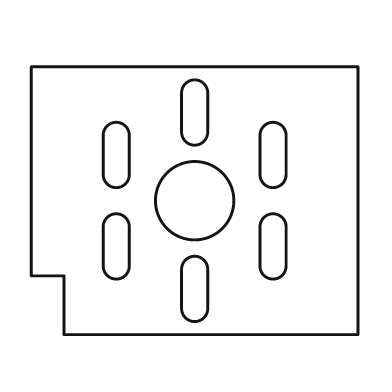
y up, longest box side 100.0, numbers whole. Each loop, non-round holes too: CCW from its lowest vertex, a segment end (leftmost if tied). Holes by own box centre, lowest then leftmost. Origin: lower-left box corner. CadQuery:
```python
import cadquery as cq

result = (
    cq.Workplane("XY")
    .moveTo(10.0, 0.0)
    .lineTo(100.0, 0.0)
    .lineTo(100.0, 82.0)
    .lineTo(0.0, 82.0)
    .lineTo(0.0, 18.0)
    .lineTo(10.0, 18.0)
    .close()
    .moveTo(46.0, 8.0)
    .threePointArc((50.0, 4.0), (54.0, 8.0))
    .lineTo(54.0, 20.0)
    .threePointArc((50.0, 24.0), (46.0, 20.0))
    .close()
    .moveTo(22.0, 21.0)
    .threePointArc((26.0, 17.0), (30.0, 21.0))
    .lineTo(30.0, 33.0)
    .threePointArc((26.0, 37.0), (22.0, 33.0))
    .close()
    .moveTo(70.0, 21.0)
    .threePointArc((74.0, 17.0), (78.0, 21.0))
    .lineTo(78.0, 33.0)
    .threePointArc((74.0, 37.0), (70.0, 33.0))
    .close()
    .moveTo(50.0, 41.0)
    .circle(12.0)
    .moveTo(22.0, 49.0)
    .threePointArc((26.0, 45.0), (30.0, 49.0))
    .lineTo(30.0, 61.0)
    .threePointArc((26.0, 65.0), (22.0, 61.0))
    .close()
    .moveTo(70.0, 49.0)
    .threePointArc((74.0, 45.0), (78.0, 49.0))
    .lineTo(78.0, 61.0)
    .threePointArc((74.0, 65.0), (70.0, 61.0))
    .close()
    .moveTo(46.0, 62.0)
    .threePointArc((50.0, 58.0), (54.0, 62.0))
    .lineTo(54.0, 74.0)
    .threePointArc((50.0, 78.0), (46.0, 74.0))
    .close()
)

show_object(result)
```